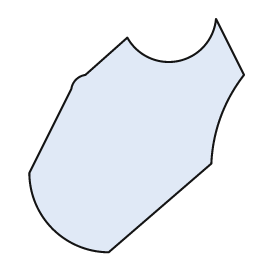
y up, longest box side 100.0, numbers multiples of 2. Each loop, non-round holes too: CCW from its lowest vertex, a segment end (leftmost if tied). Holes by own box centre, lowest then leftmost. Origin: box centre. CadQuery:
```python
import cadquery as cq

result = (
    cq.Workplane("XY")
    .moveTo(-12.0, -50.0)
    .lineTo(32.0, -12.0)
    .threePointArc((36.0, 8.0), (46.0, 26.0))
    .lineTo(34.0, 50.0)
    .threePointArc((18.0, 32.0), (-4.0, 42.0))
    .lineTo(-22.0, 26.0)
    .threePointArc((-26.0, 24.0), (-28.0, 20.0))
    .lineTo(-46.0, -16.0)
    .threePointArc((-36.0, -40.0), (-12.0, -50.0))
    .close()
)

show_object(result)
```